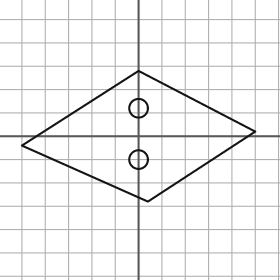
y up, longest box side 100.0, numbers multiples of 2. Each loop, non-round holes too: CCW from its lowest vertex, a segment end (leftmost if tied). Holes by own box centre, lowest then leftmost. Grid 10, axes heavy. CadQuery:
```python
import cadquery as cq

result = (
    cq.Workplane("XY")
    .moveTo(4.0, -28.0)
    .lineTo(50.0, 2.0)
    .lineTo(0.0, 28.0)
    .lineTo(-50.0, -4.0)
    .close()
    .moveTo(0.0, -10.0)
    .circle(4.0)
    .moveTo(0.0, 12.0)
    .circle(4.0)
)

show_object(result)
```